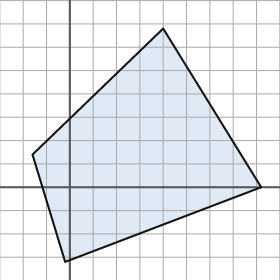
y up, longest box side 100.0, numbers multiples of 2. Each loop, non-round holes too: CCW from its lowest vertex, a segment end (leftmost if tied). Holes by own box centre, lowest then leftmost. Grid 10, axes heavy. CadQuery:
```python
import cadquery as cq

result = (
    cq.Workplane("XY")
    .moveTo(-2.0, -32.0)
    .lineTo(82.0, 0.0)
    .lineTo(40.0, 68.0)
    .lineTo(-16.0, 14.0)
    .close()
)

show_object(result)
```